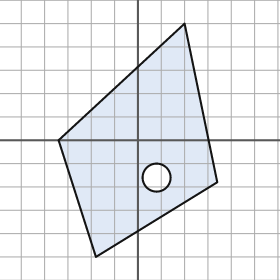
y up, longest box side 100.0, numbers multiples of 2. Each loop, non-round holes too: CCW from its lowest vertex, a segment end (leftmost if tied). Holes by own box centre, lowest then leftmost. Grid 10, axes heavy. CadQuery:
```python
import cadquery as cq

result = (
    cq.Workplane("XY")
    .moveTo(-18.0, -50.0)
    .lineTo(34.0, -18.0)
    .lineTo(20.0, 50.0)
    .lineTo(-34.0, 0.0)
    .close()
    .moveTo(8.0, -16.0)
    .circle(6.0)
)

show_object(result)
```